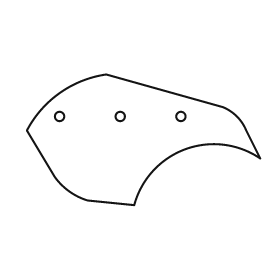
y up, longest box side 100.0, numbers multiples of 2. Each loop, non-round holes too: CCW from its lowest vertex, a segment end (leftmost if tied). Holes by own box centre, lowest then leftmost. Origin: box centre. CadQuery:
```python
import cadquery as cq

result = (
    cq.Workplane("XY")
    .moveTo(-4.0, -28.0)
    .threePointArc((18.0, -4.0), (50.0, -8.0))
    .lineTo(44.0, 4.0)
    .threePointArc((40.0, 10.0), (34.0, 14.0))
    .lineTo(-16.0, 28.0)
    .threePointArc((-36.0, 20.0), (-50.0, 4.0))
    .lineTo(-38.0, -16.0)
    .threePointArc((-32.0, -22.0), (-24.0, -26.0))
    .close()
    .moveTo(-36.0, 10.0)
    .circle(2.0)
    .moveTo(-10.0, 10.0)
    .circle(2.0)
    .moveTo(16.0, 10.0)
    .circle(2.0)
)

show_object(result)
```